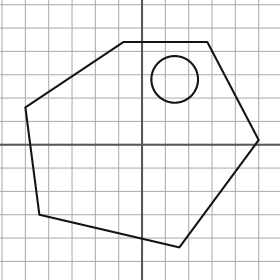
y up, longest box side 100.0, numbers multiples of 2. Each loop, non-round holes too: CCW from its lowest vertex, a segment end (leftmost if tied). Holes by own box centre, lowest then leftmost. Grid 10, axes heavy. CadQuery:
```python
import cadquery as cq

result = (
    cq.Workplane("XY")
    .moveTo(16.0, -44.0)
    .lineTo(50.0, 2.0)
    .lineTo(28.0, 44.0)
    .lineTo(-8.0, 44.0)
    .lineTo(-50.0, 16.0)
    .lineTo(-44.0, -30.0)
    .close()
    .moveTo(14.0, 28.0)
    .circle(10.0)
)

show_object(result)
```